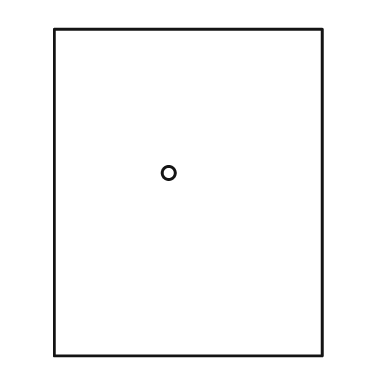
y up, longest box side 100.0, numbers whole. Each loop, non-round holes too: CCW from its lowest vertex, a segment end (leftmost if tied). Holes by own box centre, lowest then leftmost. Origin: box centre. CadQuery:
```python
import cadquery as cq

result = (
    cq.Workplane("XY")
    .moveTo(-41.0, -50.0)
    .lineTo(41.0, -50.0)
    .lineTo(41.0, 50.0)
    .lineTo(-41.0, 50.0)
    .close()
    .moveTo(-6.0, 6.0)
    .circle(2.0)
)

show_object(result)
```